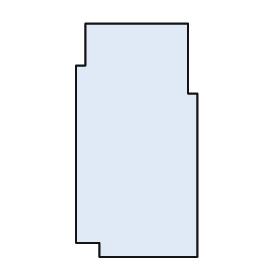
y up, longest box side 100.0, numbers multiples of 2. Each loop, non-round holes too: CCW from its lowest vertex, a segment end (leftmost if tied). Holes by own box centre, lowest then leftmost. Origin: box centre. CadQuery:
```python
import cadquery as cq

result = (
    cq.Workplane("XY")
    .moveTo(-16.0, -50.0)
    .lineTo(26.0, -50.0)
    .lineTo(26.0, 20.0)
    .lineTo(22.0, 20.0)
    .lineTo(22.0, 50.0)
    .lineTo(-22.0, 50.0)
    .lineTo(-22.0, 32.0)
    .lineTo(-26.0, 32.0)
    .lineTo(-26.0, -44.0)
    .lineTo(-16.0, -44.0)
    .close()
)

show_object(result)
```